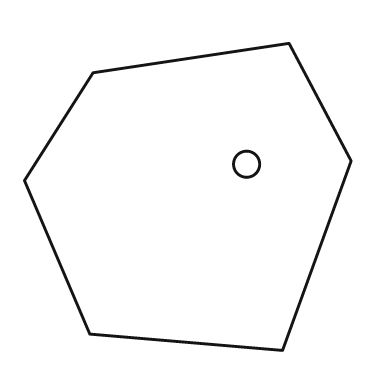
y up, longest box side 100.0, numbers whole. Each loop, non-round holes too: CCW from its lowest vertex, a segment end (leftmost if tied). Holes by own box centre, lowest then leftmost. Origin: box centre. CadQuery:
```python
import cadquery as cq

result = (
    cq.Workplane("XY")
    .moveTo(29.0, -47.0)
    .lineTo(50.0, 11.0)
    .lineTo(31.0, 47.0)
    .lineTo(-29.0, 38.0)
    .lineTo(-50.0, 5.0)
    .lineTo(-30.0, -42.0)
    .close()
    .moveTo(18.0, 10.0)
    .circle(4.0)
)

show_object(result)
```